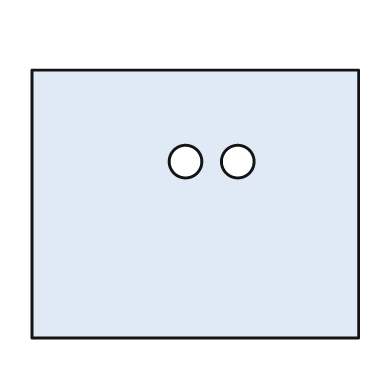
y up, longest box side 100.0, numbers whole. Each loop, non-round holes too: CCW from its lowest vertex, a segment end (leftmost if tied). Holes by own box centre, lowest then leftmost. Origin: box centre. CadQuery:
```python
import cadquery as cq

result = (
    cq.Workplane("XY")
    .moveTo(-50.0, -41.0)
    .lineTo(50.0, -41.0)
    .lineTo(50.0, 41.0)
    .lineTo(-50.0, 41.0)
    .close()
    .moveTo(-3.0, 13.0)
    .circle(5.0)
    .moveTo(13.0, 13.0)
    .circle(5.0)
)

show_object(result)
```